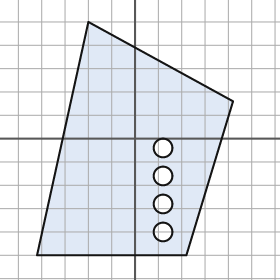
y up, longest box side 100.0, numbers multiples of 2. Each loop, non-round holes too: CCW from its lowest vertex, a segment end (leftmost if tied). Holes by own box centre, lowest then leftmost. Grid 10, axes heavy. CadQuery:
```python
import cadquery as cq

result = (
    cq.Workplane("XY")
    .moveTo(-42.0, -50.0)
    .lineTo(22.0, -50.0)
    .lineTo(42.0, 16.0)
    .lineTo(-20.0, 50.0)
    .close()
    .moveTo(12.0, -40.0)
    .circle(4.0)
    .moveTo(12.0, -28.0)
    .circle(4.0)
    .moveTo(12.0, -16.0)
    .circle(4.0)
    .moveTo(12.0, -4.0)
    .circle(4.0)
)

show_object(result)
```